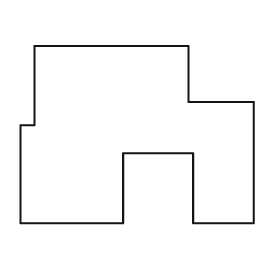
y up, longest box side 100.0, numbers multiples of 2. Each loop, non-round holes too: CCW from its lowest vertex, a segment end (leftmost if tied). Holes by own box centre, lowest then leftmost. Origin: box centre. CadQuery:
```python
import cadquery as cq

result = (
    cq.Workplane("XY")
    .moveTo(-50.0, -38.0)
    .lineTo(-6.0, -38.0)
    .lineTo(-6.0, -8.0)
    .lineTo(24.0, -8.0)
    .lineTo(24.0, -38.0)
    .lineTo(50.0, -38.0)
    .lineTo(50.0, 14.0)
    .lineTo(22.0, 14.0)
    .lineTo(22.0, 38.0)
    .lineTo(-44.0, 38.0)
    .lineTo(-44.0, 4.0)
    .lineTo(-50.0, 4.0)
    .close()
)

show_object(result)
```